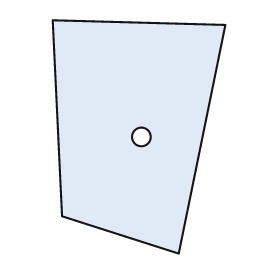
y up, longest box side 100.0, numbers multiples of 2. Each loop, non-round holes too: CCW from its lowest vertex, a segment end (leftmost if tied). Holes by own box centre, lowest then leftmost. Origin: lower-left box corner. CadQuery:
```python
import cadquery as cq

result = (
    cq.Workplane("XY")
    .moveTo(54.0, 0.0)
    .lineTo(74.0, 98.0)
    .lineTo(0.0, 100.0)
    .lineTo(4.0, 16.0)
    .close()
    .moveTo(38.0, 50.0)
    .circle(4.0)
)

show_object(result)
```